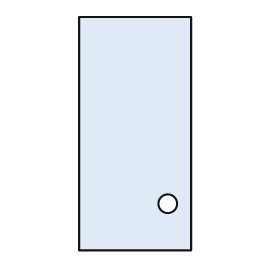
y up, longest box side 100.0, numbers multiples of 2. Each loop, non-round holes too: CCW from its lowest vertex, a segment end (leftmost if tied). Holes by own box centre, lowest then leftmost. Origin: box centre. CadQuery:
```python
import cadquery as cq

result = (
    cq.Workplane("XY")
    .moveTo(-24.0, -50.0)
    .lineTo(24.0, -50.0)
    .lineTo(24.0, 50.0)
    .lineTo(-24.0, 50.0)
    .close()
    .moveTo(14.0, -30.0)
    .circle(4.0)
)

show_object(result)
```